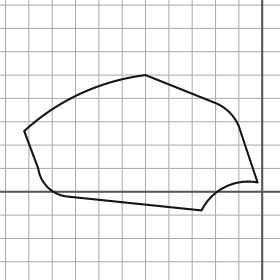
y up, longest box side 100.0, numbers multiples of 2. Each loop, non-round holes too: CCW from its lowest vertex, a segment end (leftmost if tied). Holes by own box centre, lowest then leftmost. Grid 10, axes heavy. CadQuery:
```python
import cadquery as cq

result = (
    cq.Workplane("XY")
    .moveTo(-26.0, -8.0)
    .threePointArc((-16.0, 2.0), (-2.0, 4.0))
    .lineTo(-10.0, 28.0)
    .threePointArc((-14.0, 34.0), (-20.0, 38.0))
    .lineTo(-50.0, 50.0)
    .threePointArc((-78.0, 42.0), (-102.0, 26.0))
    .lineTo(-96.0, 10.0)
    .threePointArc((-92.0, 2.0), (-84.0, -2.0))
    .close()
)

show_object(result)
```